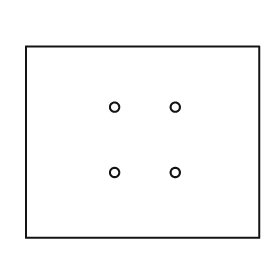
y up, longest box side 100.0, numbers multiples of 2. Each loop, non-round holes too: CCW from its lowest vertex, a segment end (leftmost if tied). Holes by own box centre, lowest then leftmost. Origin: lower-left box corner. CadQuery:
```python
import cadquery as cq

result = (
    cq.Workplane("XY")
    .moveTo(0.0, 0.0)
    .lineTo(100.0, 0.0)
    .lineTo(100.0, 82.0)
    .lineTo(0.0, 82.0)
    .close()
    .moveTo(38.0, 28.0)
    .circle(2.0)
    .moveTo(64.0, 28.0)
    .circle(2.0)
    .moveTo(38.0, 56.0)
    .circle(2.0)
    .moveTo(64.0, 56.0)
    .circle(2.0)
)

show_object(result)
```